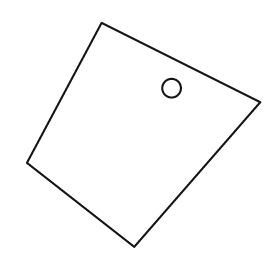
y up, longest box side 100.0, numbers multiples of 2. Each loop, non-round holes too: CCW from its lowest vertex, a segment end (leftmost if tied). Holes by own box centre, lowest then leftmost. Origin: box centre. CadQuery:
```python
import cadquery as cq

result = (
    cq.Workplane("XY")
    .moveTo(-4.0, -48.0)
    .lineTo(50.0, 14.0)
    .lineTo(-18.0, 48.0)
    .lineTo(-50.0, -12.0)
    .close()
    .moveTo(12.0, 20.0)
    .circle(4.0)
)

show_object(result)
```